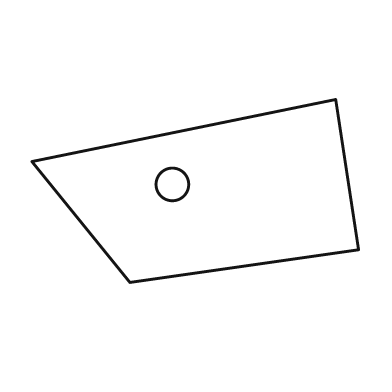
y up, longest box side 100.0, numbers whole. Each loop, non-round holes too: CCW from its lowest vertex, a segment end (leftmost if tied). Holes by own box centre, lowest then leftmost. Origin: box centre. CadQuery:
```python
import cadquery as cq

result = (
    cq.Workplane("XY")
    .moveTo(-20.0, -28.0)
    .lineTo(50.0, -18.0)
    .lineTo(43.0, 28.0)
    .lineTo(-50.0, 9.0)
    .close()
    .moveTo(-7.0, 2.0)
    .circle(5.0)
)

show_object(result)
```